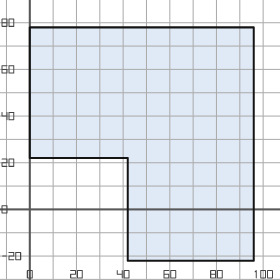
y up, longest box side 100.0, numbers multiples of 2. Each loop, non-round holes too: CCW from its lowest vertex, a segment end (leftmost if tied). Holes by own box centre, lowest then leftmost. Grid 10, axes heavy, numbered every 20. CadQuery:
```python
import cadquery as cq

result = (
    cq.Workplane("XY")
    .moveTo(42.0, -22.0)
    .lineTo(96.0, -22.0)
    .lineTo(96.0, 78.0)
    .lineTo(0.0, 78.0)
    .lineTo(0.0, 22.0)
    .lineTo(42.0, 22.0)
    .close()
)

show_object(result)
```